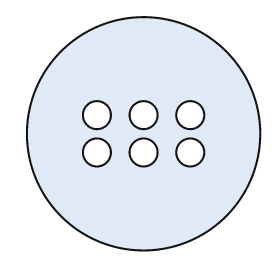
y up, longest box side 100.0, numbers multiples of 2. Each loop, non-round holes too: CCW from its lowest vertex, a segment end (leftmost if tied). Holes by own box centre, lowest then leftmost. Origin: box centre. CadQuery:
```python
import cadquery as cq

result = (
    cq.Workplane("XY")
    .moveTo(0.0, 0.0)
    .circle(50.0)
    .moveTo(-20.0, -8.0)
    .circle(6.0)
    .moveTo(0.0, -8.0)
    .circle(6.0)
    .moveTo(20.0, -8.0)
    .circle(6.0)
    .moveTo(-20.0, 8.0)
    .circle(6.0)
    .moveTo(0.0, 8.0)
    .circle(6.0)
    .moveTo(20.0, 8.0)
    .circle(6.0)
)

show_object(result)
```